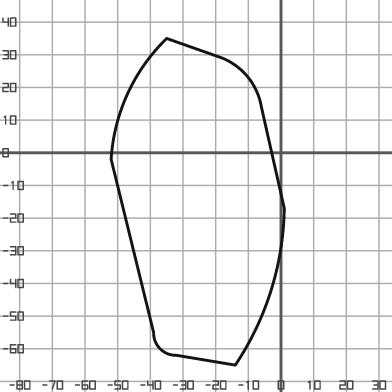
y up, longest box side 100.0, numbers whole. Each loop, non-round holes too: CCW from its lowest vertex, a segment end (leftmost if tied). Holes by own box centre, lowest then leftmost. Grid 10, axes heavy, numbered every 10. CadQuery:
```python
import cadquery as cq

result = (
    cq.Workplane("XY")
    .moveTo(-14.0, -65.0)
    .threePointArc((-3.0, -42.0), (1.0, -17.0))
    .lineTo(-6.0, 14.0)
    .threePointArc((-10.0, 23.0), (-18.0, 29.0))
    .lineTo(-35.0, 35.0)
    .threePointArc((-47.0, 18.0), (-52.0, -2.0))
    .lineTo(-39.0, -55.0)
    .threePointArc((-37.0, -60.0), (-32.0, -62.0))
    .close()
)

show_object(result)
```